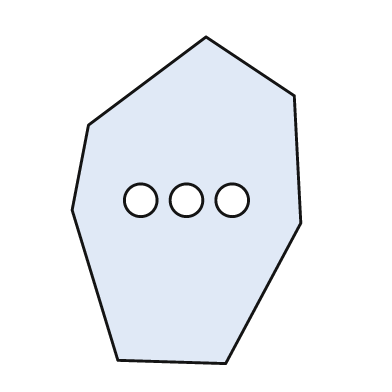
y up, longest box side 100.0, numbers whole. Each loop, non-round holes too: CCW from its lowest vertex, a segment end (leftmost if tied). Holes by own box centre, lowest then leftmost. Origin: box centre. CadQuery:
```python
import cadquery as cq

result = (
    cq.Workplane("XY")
    .moveTo(12.0, -50.0)
    .lineTo(35.0, -7.0)
    .lineTo(33.0, 32.0)
    .lineTo(6.0, 50.0)
    .lineTo(-30.0, 23.0)
    .lineTo(-35.0, -3.0)
    .lineTo(-21.0, -49.0)
    .close()
    .moveTo(-14.0, 0.0)
    .circle(5.0)
    .moveTo(0.0, 0.0)
    .circle(5.0)
    .moveTo(14.0, 0.0)
    .circle(5.0)
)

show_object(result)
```